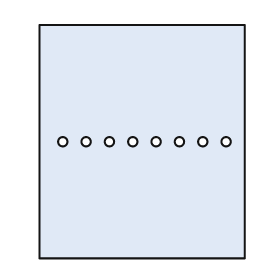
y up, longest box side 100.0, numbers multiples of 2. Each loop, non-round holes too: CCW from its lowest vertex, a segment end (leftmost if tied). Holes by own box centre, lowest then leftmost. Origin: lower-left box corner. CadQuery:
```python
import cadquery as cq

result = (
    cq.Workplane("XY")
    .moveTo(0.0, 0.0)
    .lineTo(88.0, 0.0)
    .lineTo(88.0, 100.0)
    .lineTo(0.0, 100.0)
    .close()
    .moveTo(10.0, 50.0)
    .circle(2.0)
    .moveTo(20.0, 50.0)
    .circle(2.0)
    .moveTo(30.0, 50.0)
    .circle(2.0)
    .moveTo(40.0, 50.0)
    .circle(2.0)
    .moveTo(50.0, 50.0)
    .circle(2.0)
    .moveTo(60.0, 50.0)
    .circle(2.0)
    .moveTo(70.0, 50.0)
    .circle(2.0)
    .moveTo(80.0, 50.0)
    .circle(2.0)
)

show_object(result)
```